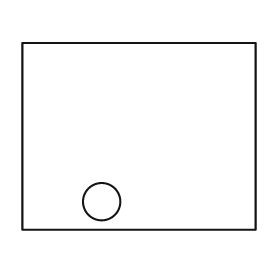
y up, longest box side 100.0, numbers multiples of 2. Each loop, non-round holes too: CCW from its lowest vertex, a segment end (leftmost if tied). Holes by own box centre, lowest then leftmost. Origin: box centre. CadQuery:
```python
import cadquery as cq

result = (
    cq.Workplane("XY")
    .moveTo(-50.0, -40.0)
    .lineTo(50.0, -40.0)
    .lineTo(50.0, 40.0)
    .lineTo(-50.0, 40.0)
    .close()
    .moveTo(-16.0, -28.0)
    .circle(8.0)
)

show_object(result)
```